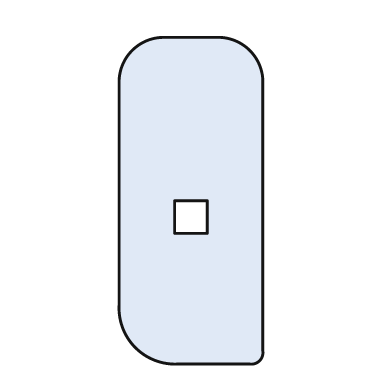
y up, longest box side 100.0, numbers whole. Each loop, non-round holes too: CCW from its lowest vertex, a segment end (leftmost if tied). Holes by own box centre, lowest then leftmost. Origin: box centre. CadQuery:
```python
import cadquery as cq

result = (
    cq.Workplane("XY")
    .moveTo(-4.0, -50.0)
    .lineTo(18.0, -50.0)
    .threePointArc((21.0, -49.0), (22.0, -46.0))
    .lineTo(22.0, 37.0)
    .threePointArc((18.0, 46.0), (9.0, 50.0))
    .lineTo(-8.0, 50.0)
    .threePointArc((-18.0, 46.0), (-22.0, 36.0))
    .lineTo(-22.0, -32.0)
    .threePointArc((-17.0, -45.0), (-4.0, -50.0))
    .close()
    .moveTo(-5.0, -10.0)
    .lineTo(5.0, -10.0)
    .lineTo(5.0, 0.0)
    .lineTo(-5.0, 0.0)
    .close()
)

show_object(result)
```